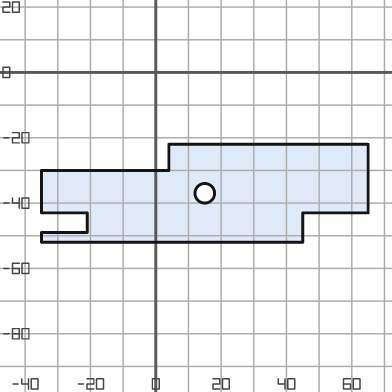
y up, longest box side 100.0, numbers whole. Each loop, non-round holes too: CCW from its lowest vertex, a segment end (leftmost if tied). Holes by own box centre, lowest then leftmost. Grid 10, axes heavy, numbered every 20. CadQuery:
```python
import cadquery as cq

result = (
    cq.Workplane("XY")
    .moveTo(-35.0, -52.0)
    .lineTo(45.0, -52.0)
    .lineTo(45.0, -43.0)
    .lineTo(65.0, -43.0)
    .lineTo(65.0, -22.0)
    .lineTo(4.0, -22.0)
    .lineTo(4.0, -30.0)
    .lineTo(-35.0, -30.0)
    .lineTo(-35.0, -43.0)
    .lineTo(-21.0, -43.0)
    .lineTo(-21.0, -49.0)
    .lineTo(-35.0, -49.0)
    .close()
    .moveTo(15.0, -37.0)
    .circle(3.0)
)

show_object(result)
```